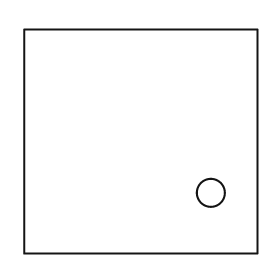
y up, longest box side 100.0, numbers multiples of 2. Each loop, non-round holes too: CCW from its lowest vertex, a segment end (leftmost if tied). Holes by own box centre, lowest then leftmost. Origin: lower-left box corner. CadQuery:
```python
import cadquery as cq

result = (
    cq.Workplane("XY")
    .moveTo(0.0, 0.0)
    .lineTo(100.0, 0.0)
    .lineTo(100.0, 96.0)
    .lineTo(0.0, 96.0)
    .close()
    .moveTo(80.0, 26.0)
    .circle(6.0)
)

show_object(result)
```